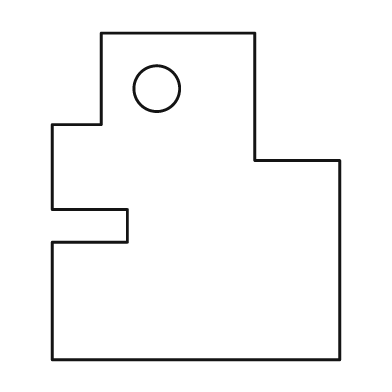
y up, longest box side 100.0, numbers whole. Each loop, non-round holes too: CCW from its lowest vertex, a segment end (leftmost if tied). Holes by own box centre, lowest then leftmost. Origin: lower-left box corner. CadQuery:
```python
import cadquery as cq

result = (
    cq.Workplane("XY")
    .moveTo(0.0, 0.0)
    .lineTo(88.0, 0.0)
    .lineTo(88.0, 61.0)
    .lineTo(62.0, 61.0)
    .lineTo(62.0, 100.0)
    .lineTo(15.0, 100.0)
    .lineTo(15.0, 72.0)
    .lineTo(0.0, 72.0)
    .lineTo(0.0, 46.0)
    .lineTo(23.0, 46.0)
    .lineTo(23.0, 36.0)
    .lineTo(0.0, 36.0)
    .close()
    .moveTo(32.0, 83.0)
    .circle(7.0)
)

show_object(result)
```